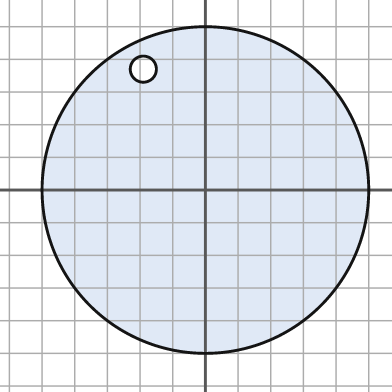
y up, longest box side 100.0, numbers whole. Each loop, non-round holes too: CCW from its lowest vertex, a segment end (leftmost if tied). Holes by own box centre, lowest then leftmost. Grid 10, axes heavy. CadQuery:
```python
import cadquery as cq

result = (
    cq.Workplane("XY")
    .moveTo(0.0, 0.0)
    .circle(50.0)
    .moveTo(-19.0, 37.0)
    .circle(4.0)
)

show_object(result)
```